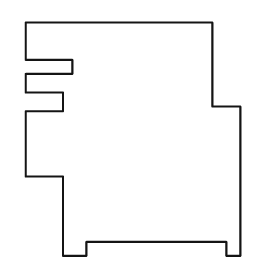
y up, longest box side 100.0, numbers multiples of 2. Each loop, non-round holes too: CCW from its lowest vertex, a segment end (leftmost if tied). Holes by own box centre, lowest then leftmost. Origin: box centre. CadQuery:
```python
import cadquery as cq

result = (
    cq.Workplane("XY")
    .moveTo(-30.0, -50.0)
    .lineTo(-20.0, -50.0)
    .lineTo(-20.0, -44.0)
    .lineTo(40.0, -44.0)
    .lineTo(40.0, -50.0)
    .lineTo(46.0, -50.0)
    .lineTo(46.0, 14.0)
    .lineTo(34.0, 14.0)
    .lineTo(34.0, 50.0)
    .lineTo(-46.0, 50.0)
    .lineTo(-46.0, 34.0)
    .lineTo(-26.0, 34.0)
    .lineTo(-26.0, 28.0)
    .lineTo(-46.0, 28.0)
    .lineTo(-46.0, 20.0)
    .lineTo(-30.0, 20.0)
    .lineTo(-30.0, 12.0)
    .lineTo(-46.0, 12.0)
    .lineTo(-46.0, -16.0)
    .lineTo(-30.0, -16.0)
    .close()
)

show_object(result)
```